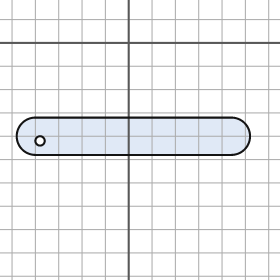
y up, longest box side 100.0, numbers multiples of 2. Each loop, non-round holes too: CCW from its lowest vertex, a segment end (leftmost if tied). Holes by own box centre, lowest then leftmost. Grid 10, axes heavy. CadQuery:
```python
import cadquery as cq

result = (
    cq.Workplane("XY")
    .moveTo(-40.0, -48.0)
    .lineTo(44.0, -48.0)
    .threePointArc((52.0, -40.0), (44.0, -32.0))
    .lineTo(-40.0, -32.0)
    .threePointArc((-48.0, -40.0), (-40.0, -48.0))
    .close()
    .moveTo(-38.0, -42.0)
    .circle(2.0)
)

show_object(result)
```